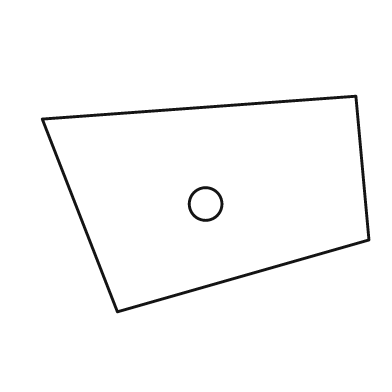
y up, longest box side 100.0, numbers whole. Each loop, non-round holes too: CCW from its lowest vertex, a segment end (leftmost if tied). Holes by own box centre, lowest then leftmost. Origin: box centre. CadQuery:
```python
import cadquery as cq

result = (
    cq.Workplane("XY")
    .moveTo(-27.0, -33.0)
    .lineTo(50.0, -11.0)
    .lineTo(46.0, 33.0)
    .lineTo(-50.0, 26.0)
    .close()
    .moveTo(0.0, 0.0)
    .circle(5.0)
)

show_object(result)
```